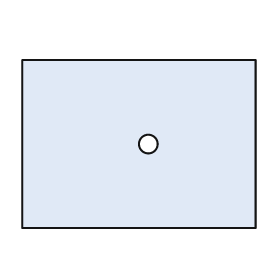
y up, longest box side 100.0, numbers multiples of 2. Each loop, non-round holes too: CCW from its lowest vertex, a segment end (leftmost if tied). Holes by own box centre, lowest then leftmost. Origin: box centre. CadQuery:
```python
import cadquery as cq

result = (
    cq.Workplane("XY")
    .moveTo(-50.0, -36.0)
    .lineTo(50.0, -36.0)
    .lineTo(50.0, 36.0)
    .lineTo(-50.0, 36.0)
    .close()
    .moveTo(4.0, 0.0)
    .circle(4.0)
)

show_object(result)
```